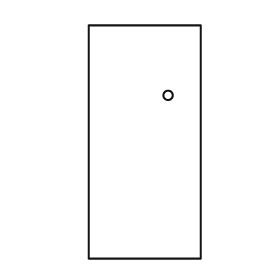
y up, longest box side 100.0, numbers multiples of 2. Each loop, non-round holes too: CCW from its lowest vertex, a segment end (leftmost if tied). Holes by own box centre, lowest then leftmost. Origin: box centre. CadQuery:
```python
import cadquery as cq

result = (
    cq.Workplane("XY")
    .moveTo(-24.0, -50.0)
    .lineTo(24.0, -50.0)
    .lineTo(24.0, 50.0)
    .lineTo(-24.0, 50.0)
    .close()
    .moveTo(10.0, 20.0)
    .circle(2.0)
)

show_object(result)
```